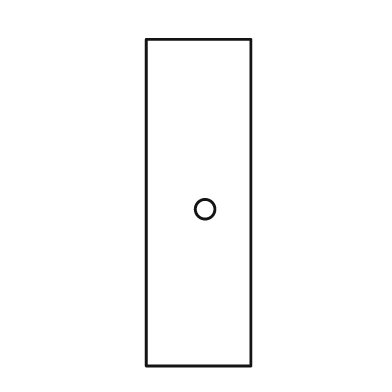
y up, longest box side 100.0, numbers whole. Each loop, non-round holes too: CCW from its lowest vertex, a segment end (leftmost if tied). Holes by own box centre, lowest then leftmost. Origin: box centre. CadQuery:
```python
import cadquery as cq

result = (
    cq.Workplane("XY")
    .moveTo(-16.0, -50.0)
    .lineTo(16.0, -50.0)
    .lineTo(16.0, 50.0)
    .lineTo(-16.0, 50.0)
    .close()
    .moveTo(2.0, -2.0)
    .circle(3.0)
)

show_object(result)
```